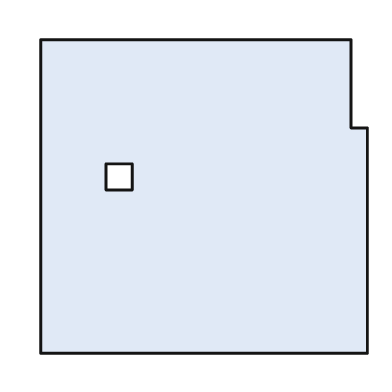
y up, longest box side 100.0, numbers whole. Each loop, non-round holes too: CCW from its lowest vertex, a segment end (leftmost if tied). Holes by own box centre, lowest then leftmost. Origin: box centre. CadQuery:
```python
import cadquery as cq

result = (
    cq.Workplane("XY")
    .moveTo(-50.0, -48.0)
    .lineTo(50.0, -48.0)
    .lineTo(50.0, 21.0)
    .lineTo(45.0, 21.0)
    .lineTo(45.0, 48.0)
    .lineTo(-50.0, 48.0)
    .close()
    .moveTo(-30.0, 2.0)
    .lineTo(-22.0, 2.0)
    .lineTo(-22.0, 10.0)
    .lineTo(-30.0, 10.0)
    .close()
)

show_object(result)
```